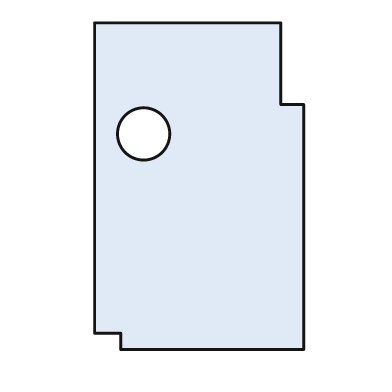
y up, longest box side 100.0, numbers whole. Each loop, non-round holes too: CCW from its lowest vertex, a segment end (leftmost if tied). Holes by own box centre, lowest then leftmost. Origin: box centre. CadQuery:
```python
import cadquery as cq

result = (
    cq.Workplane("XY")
    .moveTo(-24.0, -50.0)
    .lineTo(32.0, -50.0)
    .lineTo(32.0, 25.0)
    .lineTo(25.0, 25.0)
    .lineTo(25.0, 50.0)
    .lineTo(-32.0, 50.0)
    .lineTo(-32.0, -45.0)
    .lineTo(-24.0, -45.0)
    .close()
    .moveTo(-17.0, 16.0)
    .circle(8.0)
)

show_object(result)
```